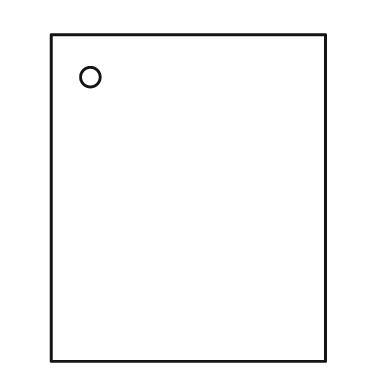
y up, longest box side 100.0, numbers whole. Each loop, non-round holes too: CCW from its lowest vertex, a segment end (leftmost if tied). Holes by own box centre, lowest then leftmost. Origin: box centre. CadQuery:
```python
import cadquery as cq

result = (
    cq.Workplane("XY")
    .moveTo(-42.0, -50.0)
    .lineTo(42.0, -50.0)
    .lineTo(42.0, 50.0)
    .lineTo(-42.0, 50.0)
    .close()
    .moveTo(-30.0, 37.0)
    .circle(3.0)
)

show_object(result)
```